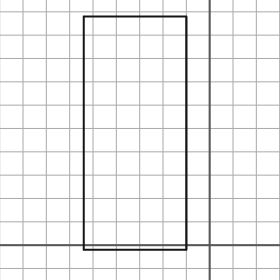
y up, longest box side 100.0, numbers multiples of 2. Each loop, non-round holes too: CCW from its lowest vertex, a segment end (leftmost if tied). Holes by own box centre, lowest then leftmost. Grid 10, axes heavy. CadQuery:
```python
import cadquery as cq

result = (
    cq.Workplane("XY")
    .moveTo(-54.0, -2.0)
    .lineTo(-10.0, -2.0)
    .lineTo(-10.0, 98.0)
    .lineTo(-54.0, 98.0)
    .close()
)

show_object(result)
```